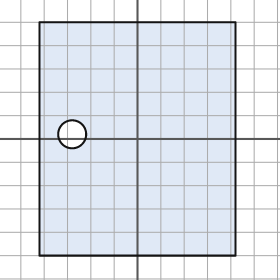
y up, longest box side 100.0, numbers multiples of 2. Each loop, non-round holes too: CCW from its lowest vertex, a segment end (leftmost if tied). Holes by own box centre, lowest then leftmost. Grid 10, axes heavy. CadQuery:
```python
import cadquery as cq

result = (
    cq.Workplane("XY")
    .moveTo(-42.0, -50.0)
    .lineTo(42.0, -50.0)
    .lineTo(42.0, 50.0)
    .lineTo(-42.0, 50.0)
    .close()
    .moveTo(-28.0, 2.0)
    .circle(6.0)
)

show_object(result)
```